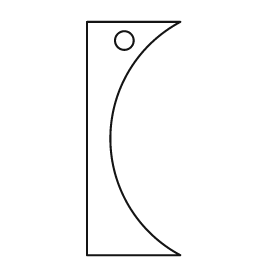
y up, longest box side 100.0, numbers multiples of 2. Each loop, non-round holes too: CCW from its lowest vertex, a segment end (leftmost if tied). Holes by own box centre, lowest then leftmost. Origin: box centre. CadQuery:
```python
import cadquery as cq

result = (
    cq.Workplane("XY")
    .moveTo(-20.0, -50.0)
    .lineTo(20.0, -50.0)
    .threePointArc((-10.0, 0.0), (20.0, 50.0))
    .lineTo(-20.0, 50.0)
    .close()
    .moveTo(-4.0, 42.0)
    .circle(4.0)
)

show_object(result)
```